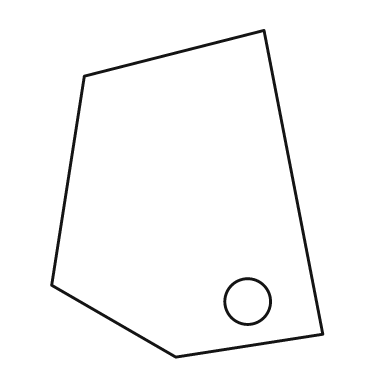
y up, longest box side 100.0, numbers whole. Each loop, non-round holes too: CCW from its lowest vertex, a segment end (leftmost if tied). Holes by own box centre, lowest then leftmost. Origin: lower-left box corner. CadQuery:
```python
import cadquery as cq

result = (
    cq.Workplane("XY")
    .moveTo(38.0, 0.0)
    .lineTo(83.0, 7.0)
    .lineTo(65.0, 100.0)
    .lineTo(10.0, 86.0)
    .lineTo(0.0, 22.0)
    .close()
    .moveTo(60.0, 17.0)
    .circle(7.0)
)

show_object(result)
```